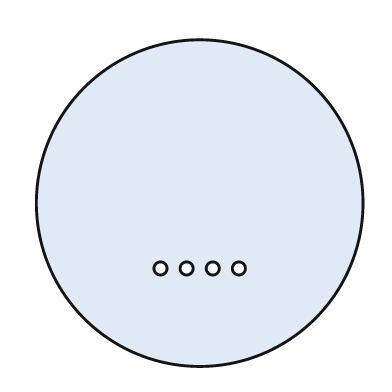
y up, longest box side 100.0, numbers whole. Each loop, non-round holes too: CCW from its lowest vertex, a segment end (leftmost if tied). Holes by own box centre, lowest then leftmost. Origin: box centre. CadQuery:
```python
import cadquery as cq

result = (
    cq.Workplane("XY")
    .moveTo(0.0, 0.0)
    .circle(50.0)
    .moveTo(-12.0, -20.0)
    .circle(2.0)
    .moveTo(-4.0, -20.0)
    .circle(2.0)
    .moveTo(4.0, -20.0)
    .circle(2.0)
    .moveTo(12.0, -20.0)
    .circle(2.0)
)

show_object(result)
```